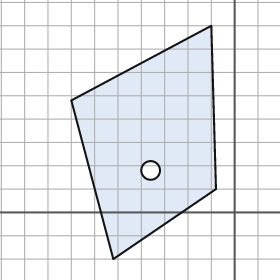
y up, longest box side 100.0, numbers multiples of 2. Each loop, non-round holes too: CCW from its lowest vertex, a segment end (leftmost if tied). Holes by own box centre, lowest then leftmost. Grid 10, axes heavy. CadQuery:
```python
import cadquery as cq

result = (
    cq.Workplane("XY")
    .moveTo(-52.0, -20.0)
    .lineTo(-8.0, 10.0)
    .lineTo(-10.0, 80.0)
    .lineTo(-70.0, 48.0)
    .close()
    .moveTo(-36.0, 18.0)
    .circle(4.0)
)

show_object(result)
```